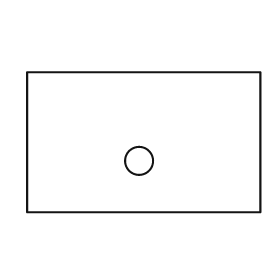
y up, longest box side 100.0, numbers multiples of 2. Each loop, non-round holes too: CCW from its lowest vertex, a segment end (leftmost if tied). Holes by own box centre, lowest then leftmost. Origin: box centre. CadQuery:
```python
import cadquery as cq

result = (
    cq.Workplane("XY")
    .moveTo(-50.0, -30.0)
    .lineTo(50.0, -30.0)
    .lineTo(50.0, 30.0)
    .lineTo(-50.0, 30.0)
    .close()
    .moveTo(-2.0, -8.0)
    .circle(6.0)
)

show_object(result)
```